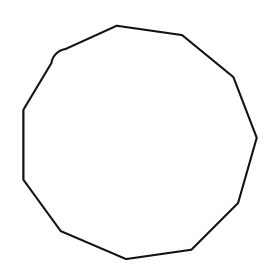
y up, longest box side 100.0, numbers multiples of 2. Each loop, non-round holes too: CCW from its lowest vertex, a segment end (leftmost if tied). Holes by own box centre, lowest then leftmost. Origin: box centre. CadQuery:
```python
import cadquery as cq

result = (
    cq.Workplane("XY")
    .moveTo(-6.0, -50.0)
    .lineTo(22.0, -46.0)
    .lineTo(42.0, -26.0)
    .lineTo(50.0, 2.0)
    .lineTo(40.0, 28.0)
    .lineTo(18.0, 46.0)
    .lineTo(-10.0, 50.0)
    .lineTo(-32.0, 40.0)
    .threePointArc((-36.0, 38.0), (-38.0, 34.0))
    .lineTo(-50.0, 14.0)
    .lineTo(-50.0, -16.0)
    .lineTo(-34.0, -38.0)
    .close()
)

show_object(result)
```